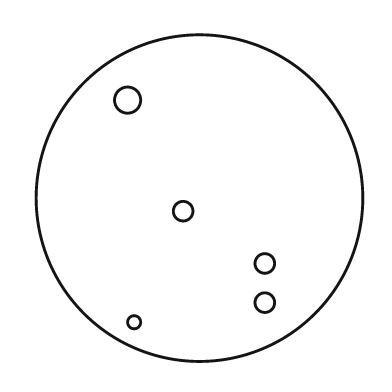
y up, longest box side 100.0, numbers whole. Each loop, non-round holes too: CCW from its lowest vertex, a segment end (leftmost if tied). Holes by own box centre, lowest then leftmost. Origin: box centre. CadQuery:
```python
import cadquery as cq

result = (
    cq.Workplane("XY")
    .moveTo(0.0, 0.0)
    .circle(50.0)
    .moveTo(-20.0, -38.0)
    .circle(2.0)
    .moveTo(20.0, -32.0)
    .circle(3.0)
    .moveTo(20.0, -20.0)
    .circle(3.0)
    .moveTo(-5.0, -4.0)
    .circle(3.0)
    .moveTo(-22.0, 30.0)
    .circle(4.0)
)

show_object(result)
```